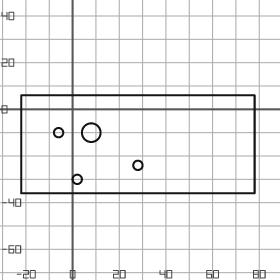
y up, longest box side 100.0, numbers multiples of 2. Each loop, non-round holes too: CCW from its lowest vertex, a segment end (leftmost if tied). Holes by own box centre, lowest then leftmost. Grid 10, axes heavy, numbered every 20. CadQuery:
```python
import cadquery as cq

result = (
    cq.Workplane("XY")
    .moveTo(-22.0, -36.0)
    .lineTo(78.0, -36.0)
    .lineTo(78.0, 6.0)
    .lineTo(-22.0, 6.0)
    .close()
    .moveTo(2.0, -30.0)
    .circle(2.0)
    .moveTo(28.0, -24.0)
    .circle(2.0)
    .moveTo(-6.0, -10.0)
    .circle(2.0)
    .moveTo(8.0, -10.0)
    .circle(4.0)
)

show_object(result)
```